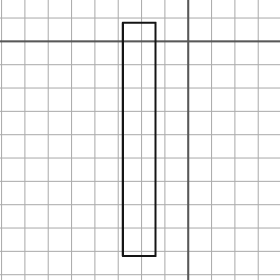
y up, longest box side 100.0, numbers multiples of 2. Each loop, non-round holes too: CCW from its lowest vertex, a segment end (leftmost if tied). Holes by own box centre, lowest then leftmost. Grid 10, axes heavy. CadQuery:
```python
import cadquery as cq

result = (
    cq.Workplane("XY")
    .moveTo(-28.0, -92.0)
    .lineTo(-14.0, -92.0)
    .lineTo(-14.0, 8.0)
    .lineTo(-28.0, 8.0)
    .close()
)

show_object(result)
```